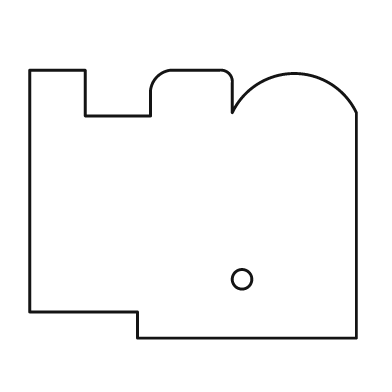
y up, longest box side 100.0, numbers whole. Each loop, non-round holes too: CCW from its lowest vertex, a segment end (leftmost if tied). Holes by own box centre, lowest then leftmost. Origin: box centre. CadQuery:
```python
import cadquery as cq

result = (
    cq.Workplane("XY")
    .moveTo(-17.0, -41.0)
    .lineTo(50.0, -41.0)
    .lineTo(50.0, 28.0)
    .threePointArc((31.0, 40.0), (12.0, 28.0))
    .lineTo(12.0, 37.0)
    .threePointArc((11.0, 40.0), (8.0, 41.0))
    .lineTo(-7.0, 41.0)
    .threePointArc((-11.0, 39.0), (-13.0, 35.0))
    .lineTo(-13.0, 27.0)
    .lineTo(-33.0, 27.0)
    .lineTo(-33.0, 41.0)
    .lineTo(-50.0, 41.0)
    .lineTo(-50.0, -33.0)
    .lineTo(-17.0, -33.0)
    .close()
    .moveTo(15.0, -23.0)
    .circle(3.0)
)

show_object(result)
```